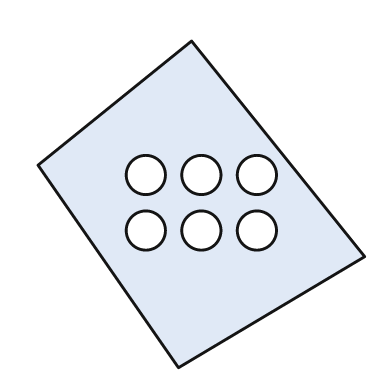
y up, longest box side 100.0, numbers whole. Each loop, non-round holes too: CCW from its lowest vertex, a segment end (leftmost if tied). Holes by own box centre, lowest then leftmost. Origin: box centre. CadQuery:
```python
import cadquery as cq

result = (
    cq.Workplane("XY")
    .moveTo(-7.0, -50.0)
    .lineTo(50.0, -16.0)
    .lineTo(-3.0, 50.0)
    .lineTo(-50.0, 12.0)
    .close()
    .moveTo(-17.0, -8.0)
    .circle(6.0)
    .moveTo(0.0, -8.0)
    .circle(6.0)
    .moveTo(17.0, -8.0)
    .circle(6.0)
    .moveTo(-17.0, 9.0)
    .circle(6.0)
    .moveTo(0.0, 9.0)
    .circle(6.0)
    .moveTo(17.0, 9.0)
    .circle(6.0)
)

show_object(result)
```